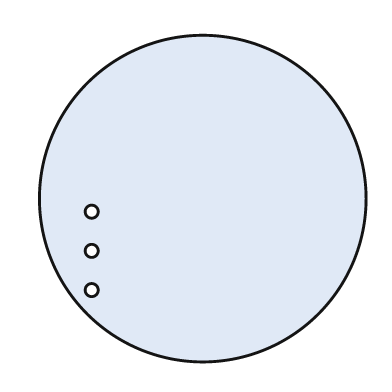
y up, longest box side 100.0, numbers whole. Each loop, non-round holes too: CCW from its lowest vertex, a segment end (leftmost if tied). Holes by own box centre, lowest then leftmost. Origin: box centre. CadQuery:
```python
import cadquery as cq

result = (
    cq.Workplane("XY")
    .moveTo(0.0, 0.0)
    .circle(50.0)
    .moveTo(-34.0, -28.0)
    .circle(2.0)
    .moveTo(-34.0, -16.0)
    .circle(2.0)
    .moveTo(-34.0, -4.0)
    .circle(2.0)
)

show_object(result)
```